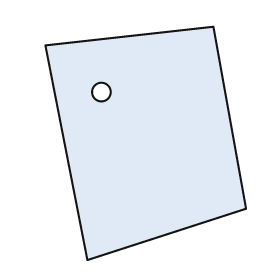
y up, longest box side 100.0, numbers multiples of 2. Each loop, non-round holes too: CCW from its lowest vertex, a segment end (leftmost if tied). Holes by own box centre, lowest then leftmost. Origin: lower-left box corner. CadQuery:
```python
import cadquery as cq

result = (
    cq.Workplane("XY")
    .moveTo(18.0, 0.0)
    .lineTo(86.0, 22.0)
    .lineTo(72.0, 100.0)
    .lineTo(0.0, 92.0)
    .close()
    .moveTo(24.0, 72.0)
    .circle(4.0)
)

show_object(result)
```